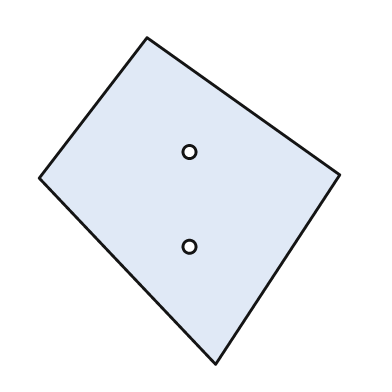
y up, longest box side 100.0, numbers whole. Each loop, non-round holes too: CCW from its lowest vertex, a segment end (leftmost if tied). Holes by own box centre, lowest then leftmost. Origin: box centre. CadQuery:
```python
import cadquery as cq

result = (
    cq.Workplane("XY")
    .moveTo(8.0, -50.0)
    .lineTo(46.0, 8.0)
    .lineTo(-13.0, 50.0)
    .lineTo(-46.0, 7.0)
    .close()
    .moveTo(0.0, -14.0)
    .circle(2.0)
    .moveTo(0.0, 15.0)
    .circle(2.0)
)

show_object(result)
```